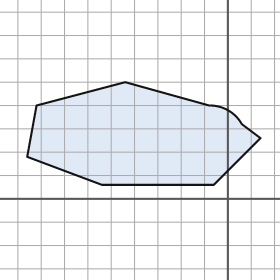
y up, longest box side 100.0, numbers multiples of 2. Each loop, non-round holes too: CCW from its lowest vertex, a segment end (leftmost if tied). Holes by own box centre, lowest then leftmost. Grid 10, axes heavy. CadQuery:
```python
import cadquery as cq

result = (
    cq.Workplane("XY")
    .moveTo(-54.0, 6.0)
    .lineTo(-6.0, 6.0)
    .lineTo(14.0, 26.0)
    .lineTo(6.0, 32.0)
    .threePointArc((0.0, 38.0), (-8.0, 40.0))
    .lineTo(-44.0, 50.0)
    .lineTo(-82.0, 40.0)
    .lineTo(-86.0, 18.0)
    .close()
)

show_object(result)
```